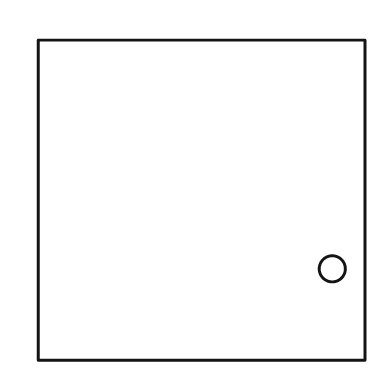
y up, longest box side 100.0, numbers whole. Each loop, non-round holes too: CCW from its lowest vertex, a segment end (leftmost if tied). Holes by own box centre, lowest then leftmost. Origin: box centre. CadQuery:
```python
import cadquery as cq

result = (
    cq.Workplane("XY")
    .moveTo(-50.0, -49.0)
    .lineTo(50.0, -49.0)
    .lineTo(50.0, 49.0)
    .lineTo(-50.0, 49.0)
    .close()
    .moveTo(40.0, -21.0)
    .circle(4.0)
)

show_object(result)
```